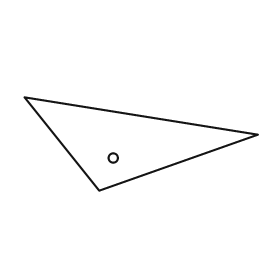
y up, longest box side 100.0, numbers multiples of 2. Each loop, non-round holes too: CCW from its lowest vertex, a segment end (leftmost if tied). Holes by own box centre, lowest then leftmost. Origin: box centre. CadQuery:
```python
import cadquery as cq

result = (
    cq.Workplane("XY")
    .moveTo(-18.0, -20.0)
    .lineTo(50.0, 4.0)
    .lineTo(-50.0, 20.0)
    .close()
    .moveTo(-12.0, -6.0)
    .circle(2.0)
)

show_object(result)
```